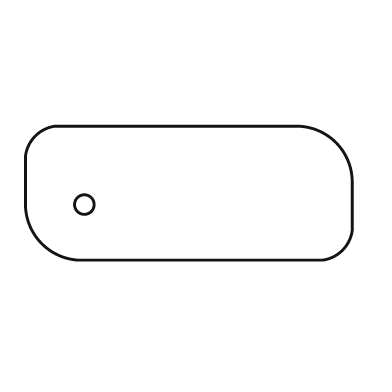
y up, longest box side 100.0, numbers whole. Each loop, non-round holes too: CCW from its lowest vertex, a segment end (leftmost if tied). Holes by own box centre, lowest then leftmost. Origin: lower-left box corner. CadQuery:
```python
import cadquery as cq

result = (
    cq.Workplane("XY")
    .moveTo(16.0, 0.0)
    .lineTo(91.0, 0.0)
    .threePointArc((97.0, 3.0), (100.0, 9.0))
    .lineTo(100.0, 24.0)
    .threePointArc((95.0, 36.0), (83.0, 41.0))
    .lineTo(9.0, 41.0)
    .threePointArc((3.0, 38.0), (0.0, 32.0))
    .lineTo(0.0, 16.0)
    .threePointArc((5.0, 5.0), (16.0, 0.0))
    .close()
    .moveTo(18.0, 17.0)
    .circle(3.0)
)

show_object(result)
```